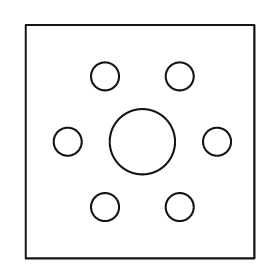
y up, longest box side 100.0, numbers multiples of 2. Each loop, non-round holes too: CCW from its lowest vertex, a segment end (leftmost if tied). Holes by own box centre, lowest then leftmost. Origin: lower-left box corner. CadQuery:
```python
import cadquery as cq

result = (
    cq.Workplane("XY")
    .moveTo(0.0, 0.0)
    .lineTo(98.0, 0.0)
    .lineTo(98.0, 100.0)
    .lineTo(0.0, 100.0)
    .close()
    .moveTo(34.0, 22.0)
    .circle(6.0)
    .moveTo(66.0, 22.0)
    .circle(6.0)
    .moveTo(18.0, 50.0)
    .circle(6.0)
    .moveTo(50.0, 50.0)
    .circle(14.0)
    .moveTo(82.0, 50.0)
    .circle(6.0)
    .moveTo(34.0, 78.0)
    .circle(6.0)
    .moveTo(66.0, 78.0)
    .circle(6.0)
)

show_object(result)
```